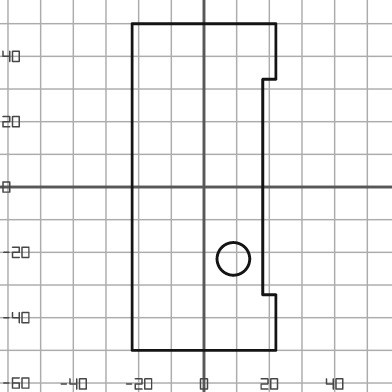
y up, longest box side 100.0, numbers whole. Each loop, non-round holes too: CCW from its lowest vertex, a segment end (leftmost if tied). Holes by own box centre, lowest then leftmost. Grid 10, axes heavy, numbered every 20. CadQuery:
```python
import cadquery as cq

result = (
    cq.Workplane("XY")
    .moveTo(-22.0, -50.0)
    .lineTo(22.0, -50.0)
    .lineTo(22.0, -33.0)
    .lineTo(18.0, -33.0)
    .lineTo(18.0, 33.0)
    .lineTo(22.0, 33.0)
    .lineTo(22.0, 50.0)
    .lineTo(-22.0, 50.0)
    .close()
    .moveTo(9.0, -22.0)
    .circle(5.0)
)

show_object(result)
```